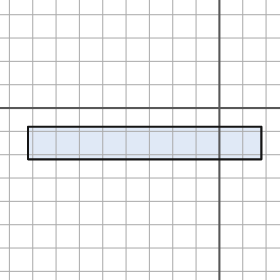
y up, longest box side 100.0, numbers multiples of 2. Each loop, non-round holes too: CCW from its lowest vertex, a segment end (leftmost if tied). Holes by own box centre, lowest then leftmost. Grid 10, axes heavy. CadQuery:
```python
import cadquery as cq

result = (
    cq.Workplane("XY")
    .moveTo(-82.0, -22.0)
    .lineTo(18.0, -22.0)
    .lineTo(18.0, -8.0)
    .lineTo(-82.0, -8.0)
    .close()
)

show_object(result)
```